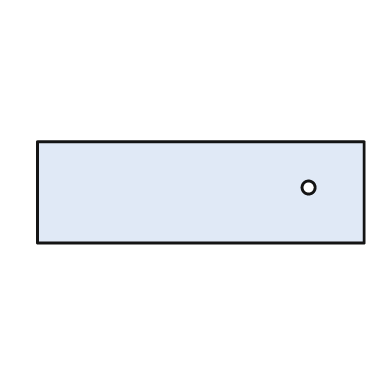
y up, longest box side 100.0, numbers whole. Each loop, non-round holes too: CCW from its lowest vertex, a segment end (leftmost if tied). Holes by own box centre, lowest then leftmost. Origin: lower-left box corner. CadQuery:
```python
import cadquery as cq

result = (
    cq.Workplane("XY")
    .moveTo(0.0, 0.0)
    .lineTo(100.0, 0.0)
    .lineTo(100.0, 31.0)
    .lineTo(0.0, 31.0)
    .close()
    .moveTo(83.0, 17.0)
    .circle(2.0)
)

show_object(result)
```